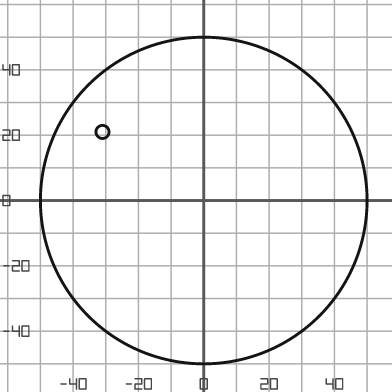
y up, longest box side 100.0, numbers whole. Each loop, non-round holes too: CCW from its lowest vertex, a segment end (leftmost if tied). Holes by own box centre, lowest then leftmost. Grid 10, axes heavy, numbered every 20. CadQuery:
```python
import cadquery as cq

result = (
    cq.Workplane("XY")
    .moveTo(0.0, 0.0)
    .circle(50.0)
    .moveTo(-31.0, 21.0)
    .circle(2.0)
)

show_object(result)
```